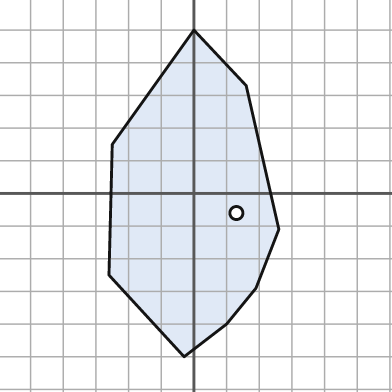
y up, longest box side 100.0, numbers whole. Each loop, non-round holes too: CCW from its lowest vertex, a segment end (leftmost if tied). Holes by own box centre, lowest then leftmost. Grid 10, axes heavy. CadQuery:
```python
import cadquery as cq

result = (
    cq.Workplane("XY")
    .moveTo(-3.0, -50.0)
    .lineTo(10.0, -40.0)
    .lineTo(19.0, -29.0)
    .lineTo(26.0, -11.0)
    .lineTo(16.0, 33.0)
    .lineTo(0.0, 50.0)
    .lineTo(-25.0, 15.0)
    .lineTo(-26.0, -25.0)
    .close()
    .moveTo(13.0, -6.0)
    .circle(2.0)
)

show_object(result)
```